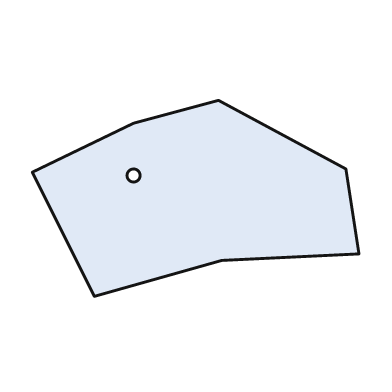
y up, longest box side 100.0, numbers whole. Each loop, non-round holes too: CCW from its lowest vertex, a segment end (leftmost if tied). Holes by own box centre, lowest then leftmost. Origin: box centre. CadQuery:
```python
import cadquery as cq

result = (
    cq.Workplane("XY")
    .moveTo(-31.0, -30.0)
    .lineTo(8.0, -19.0)
    .lineTo(50.0, -17.0)
    .lineTo(46.0, 9.0)
    .lineTo(7.0, 30.0)
    .lineTo(-19.0, 23.0)
    .lineTo(-50.0, 8.0)
    .close()
    .moveTo(-19.0, 7.0)
    .circle(2.0)
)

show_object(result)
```